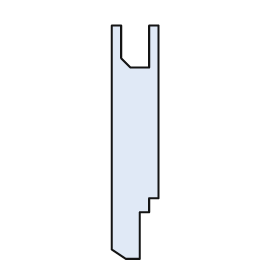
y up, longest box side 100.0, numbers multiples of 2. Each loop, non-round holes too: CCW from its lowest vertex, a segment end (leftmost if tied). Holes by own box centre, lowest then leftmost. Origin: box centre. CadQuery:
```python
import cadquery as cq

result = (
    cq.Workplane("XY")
    .moveTo(-4.0, -50.0)
    .lineTo(2.0, -50.0)
    .lineTo(2.0, -30.0)
    .lineTo(6.0, -30.0)
    .lineTo(6.0, -24.0)
    .lineTo(10.0, -24.0)
    .lineTo(10.0, 50.0)
    .lineTo(6.0, 50.0)
    .lineTo(6.0, 32.0)
    .lineTo(-2.0, 32.0)
    .lineTo(-6.0, 36.0)
    .lineTo(-6.0, 50.0)
    .lineTo(-10.0, 50.0)
    .lineTo(-10.0, -46.0)
    .close()
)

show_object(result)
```